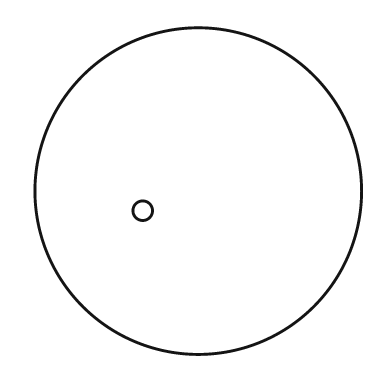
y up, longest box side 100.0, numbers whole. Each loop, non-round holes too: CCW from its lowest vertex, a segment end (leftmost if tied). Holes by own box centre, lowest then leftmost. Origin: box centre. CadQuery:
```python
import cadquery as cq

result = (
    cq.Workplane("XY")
    .moveTo(0.0, 0.0)
    .circle(50.0)
    .moveTo(-17.0, -6.0)
    .circle(3.0)
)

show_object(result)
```